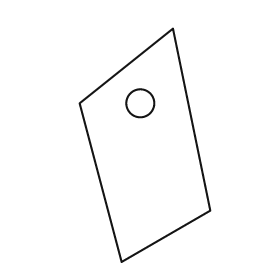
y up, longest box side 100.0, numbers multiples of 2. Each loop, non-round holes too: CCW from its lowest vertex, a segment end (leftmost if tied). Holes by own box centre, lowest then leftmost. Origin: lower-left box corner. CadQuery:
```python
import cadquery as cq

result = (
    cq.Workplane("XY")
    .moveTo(18.0, 0.0)
    .lineTo(56.0, 22.0)
    .lineTo(40.0, 100.0)
    .lineTo(0.0, 68.0)
    .close()
    .moveTo(26.0, 68.0)
    .circle(6.0)
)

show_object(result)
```